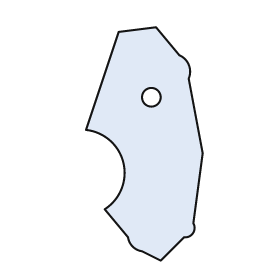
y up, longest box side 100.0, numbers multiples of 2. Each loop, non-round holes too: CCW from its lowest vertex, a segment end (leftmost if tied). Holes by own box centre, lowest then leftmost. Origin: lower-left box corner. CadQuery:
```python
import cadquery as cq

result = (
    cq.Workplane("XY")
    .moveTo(32.0, 0.0)
    .lineTo(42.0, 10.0)
    .threePointArc((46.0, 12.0), (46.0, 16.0))
    .lineTo(50.0, 46.0)
    .lineTo(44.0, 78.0)
    .threePointArc((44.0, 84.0), (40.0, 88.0))
    .lineTo(30.0, 100.0)
    .lineTo(14.0, 98.0)
    .lineTo(0.0, 56.0)
    .threePointArc((16.0, 42.0), (8.0, 22.0))
    .lineTo(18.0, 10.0)
    .threePointArc((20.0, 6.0), (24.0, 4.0))
    .close()
    .moveTo(28.0, 70.0)
    .circle(4.0)
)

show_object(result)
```